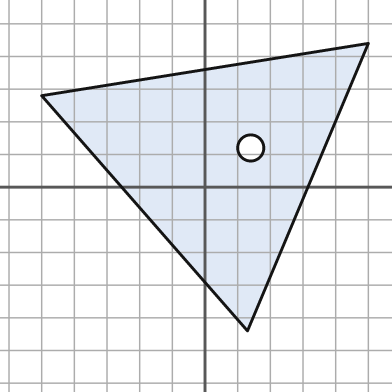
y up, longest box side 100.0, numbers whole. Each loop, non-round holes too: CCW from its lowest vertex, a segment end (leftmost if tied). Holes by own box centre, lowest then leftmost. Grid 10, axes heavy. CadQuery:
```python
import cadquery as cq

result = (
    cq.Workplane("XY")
    .moveTo(13.0, -44.0)
    .lineTo(50.0, 44.0)
    .lineTo(-50.0, 28.0)
    .close()
    .moveTo(14.0, 12.0)
    .circle(4.0)
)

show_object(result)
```